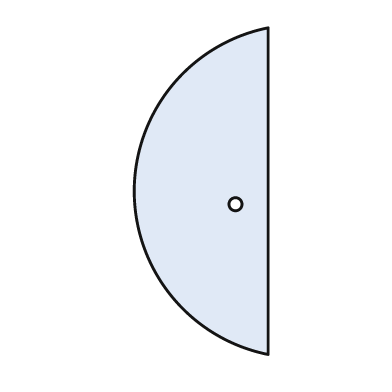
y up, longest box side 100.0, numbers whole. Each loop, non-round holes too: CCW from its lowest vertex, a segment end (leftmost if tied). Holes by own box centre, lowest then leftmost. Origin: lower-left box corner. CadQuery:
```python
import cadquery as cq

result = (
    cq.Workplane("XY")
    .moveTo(41.0, 0.0)
    .lineTo(41.0, 100.0)
    .threePointArc((0.0, 50.0), (41.0, 0.0))
    .close()
    .moveTo(31.0, 46.0)
    .circle(2.0)
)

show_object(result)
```